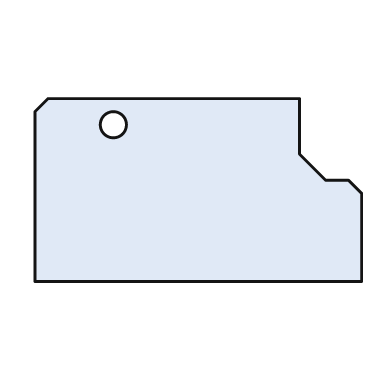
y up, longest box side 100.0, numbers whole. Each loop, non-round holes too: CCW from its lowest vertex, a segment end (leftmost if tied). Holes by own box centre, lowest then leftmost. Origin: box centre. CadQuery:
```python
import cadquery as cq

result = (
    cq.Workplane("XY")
    .moveTo(-50.0, -28.0)
    .lineTo(50.0, -28.0)
    .lineTo(50.0, -1.0)
    .lineTo(46.0, 3.0)
    .lineTo(39.0, 3.0)
    .lineTo(31.0, 11.0)
    .lineTo(31.0, 28.0)
    .lineTo(-46.0, 28.0)
    .lineTo(-50.0, 24.0)
    .close()
    .moveTo(-26.0, 20.0)
    .circle(4.0)
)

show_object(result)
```